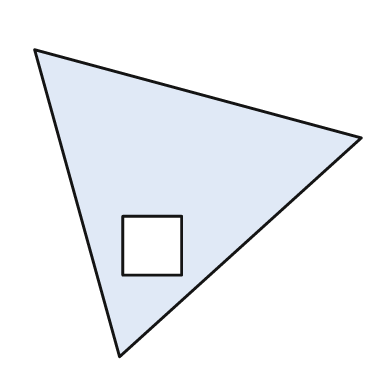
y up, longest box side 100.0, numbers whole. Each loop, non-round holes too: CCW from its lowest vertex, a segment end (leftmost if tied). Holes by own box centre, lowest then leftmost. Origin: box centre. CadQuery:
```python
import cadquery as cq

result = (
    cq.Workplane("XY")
    .moveTo(-24.0, -47.0)
    .lineTo(50.0, 20.0)
    .lineTo(-50.0, 47.0)
    .close()
    .moveTo(-23.0, -22.0)
    .lineTo(-5.0, -22.0)
    .lineTo(-5.0, -4.0)
    .lineTo(-23.0, -4.0)
    .close()
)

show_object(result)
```